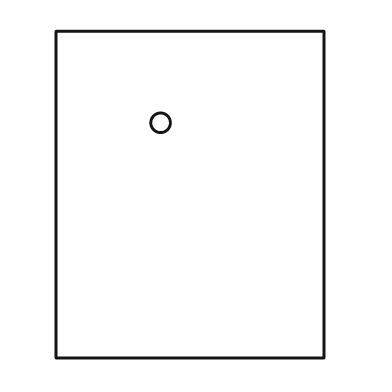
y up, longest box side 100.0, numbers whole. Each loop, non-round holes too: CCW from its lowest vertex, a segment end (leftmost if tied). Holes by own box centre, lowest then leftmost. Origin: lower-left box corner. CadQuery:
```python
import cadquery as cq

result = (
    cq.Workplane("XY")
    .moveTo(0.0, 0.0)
    .lineTo(82.0, 0.0)
    .lineTo(82.0, 100.0)
    .lineTo(0.0, 100.0)
    .close()
    .moveTo(32.0, 72.0)
    .circle(3.0)
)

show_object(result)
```